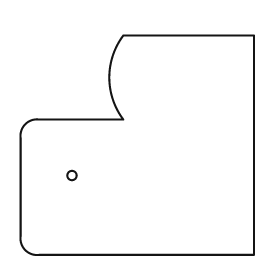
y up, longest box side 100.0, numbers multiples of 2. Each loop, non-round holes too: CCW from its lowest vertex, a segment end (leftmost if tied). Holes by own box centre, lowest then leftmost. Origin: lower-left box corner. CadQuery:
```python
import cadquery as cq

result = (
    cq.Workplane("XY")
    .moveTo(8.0, 0.0)
    .lineTo(100.0, 0.0)
    .lineTo(100.0, 94.0)
    .lineTo(44.0, 94.0)
    .threePointArc((38.0, 76.0), (44.0, 58.0))
    .lineTo(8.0, 58.0)
    .threePointArc((2.0, 56.0), (0.0, 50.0))
    .lineTo(0.0, 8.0)
    .threePointArc((2.0, 2.0), (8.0, 0.0))
    .close()
    .moveTo(22.0, 34.0)
    .circle(2.0)
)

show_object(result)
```